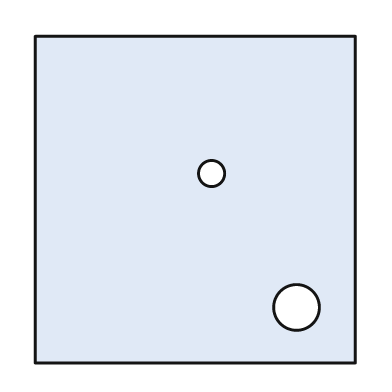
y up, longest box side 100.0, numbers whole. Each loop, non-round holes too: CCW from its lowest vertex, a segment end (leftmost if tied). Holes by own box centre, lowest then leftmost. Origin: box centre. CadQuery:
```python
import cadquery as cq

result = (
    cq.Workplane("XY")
    .moveTo(-49.0, -50.0)
    .lineTo(49.0, -50.0)
    .lineTo(49.0, 50.0)
    .lineTo(-49.0, 50.0)
    .close()
    .moveTo(31.0, -33.0)
    .circle(7.0)
    .moveTo(5.0, 8.0)
    .circle(4.0)
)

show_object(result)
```